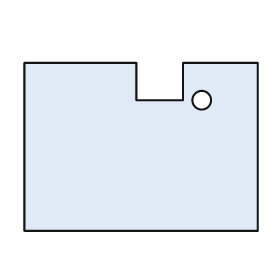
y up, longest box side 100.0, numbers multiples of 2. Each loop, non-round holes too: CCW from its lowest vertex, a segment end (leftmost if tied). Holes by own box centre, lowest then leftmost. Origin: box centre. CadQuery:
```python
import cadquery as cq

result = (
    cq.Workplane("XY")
    .moveTo(-50.0, -36.0)
    .lineTo(50.0, -36.0)
    .lineTo(50.0, 36.0)
    .lineTo(18.0, 36.0)
    .lineTo(18.0, 20.0)
    .lineTo(-2.0, 20.0)
    .lineTo(-2.0, 36.0)
    .lineTo(-50.0, 36.0)
    .close()
    .moveTo(26.0, 20.0)
    .circle(4.0)
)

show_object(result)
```